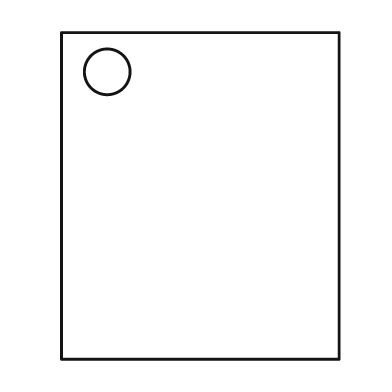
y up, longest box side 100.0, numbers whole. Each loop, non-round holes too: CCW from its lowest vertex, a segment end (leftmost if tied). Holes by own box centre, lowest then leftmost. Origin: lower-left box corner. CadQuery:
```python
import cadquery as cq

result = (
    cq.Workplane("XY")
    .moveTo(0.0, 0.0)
    .lineTo(85.0, 0.0)
    .lineTo(85.0, 100.0)
    .lineTo(0.0, 100.0)
    .close()
    .moveTo(14.0, 88.0)
    .circle(7.0)
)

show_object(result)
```